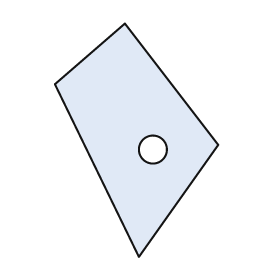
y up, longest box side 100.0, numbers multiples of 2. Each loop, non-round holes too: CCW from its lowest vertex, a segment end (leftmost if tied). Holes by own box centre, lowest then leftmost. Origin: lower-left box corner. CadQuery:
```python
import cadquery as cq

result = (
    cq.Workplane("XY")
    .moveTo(36.0, 0.0)
    .lineTo(70.0, 48.0)
    .lineTo(30.0, 100.0)
    .lineTo(0.0, 74.0)
    .close()
    .moveTo(42.0, 46.0)
    .circle(6.0)
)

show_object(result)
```